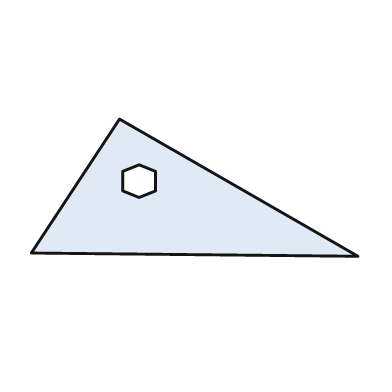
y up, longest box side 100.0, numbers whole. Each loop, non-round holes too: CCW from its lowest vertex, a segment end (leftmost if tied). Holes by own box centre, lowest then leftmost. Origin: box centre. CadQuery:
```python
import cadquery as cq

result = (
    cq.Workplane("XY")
    .moveTo(50.0, -21.0)
    .lineTo(-23.0, 21.0)
    .lineTo(-50.0, -20.0)
    .close()
    .moveTo(-17.0, -3.0)
    .lineTo(-12.0, -1.0)
    .lineTo(-12.0, 5.0)
    .lineTo(-17.0, 7.0)
    .lineTo(-22.0, 5.0)
    .lineTo(-22.0, -1.0)
    .close()
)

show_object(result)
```